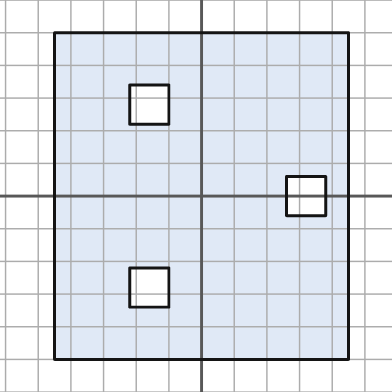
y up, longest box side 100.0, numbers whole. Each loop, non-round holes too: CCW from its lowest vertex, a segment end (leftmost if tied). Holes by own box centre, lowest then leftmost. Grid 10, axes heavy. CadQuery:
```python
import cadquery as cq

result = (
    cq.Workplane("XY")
    .moveTo(-45.0, -50.0)
    .lineTo(45.0, -50.0)
    .lineTo(45.0, 50.0)
    .lineTo(-45.0, 50.0)
    .close()
    .moveTo(-22.0, -34.0)
    .lineTo(-10.0, -34.0)
    .lineTo(-10.0, -22.0)
    .lineTo(-22.0, -22.0)
    .close()
    .moveTo(26.0, -6.0)
    .lineTo(38.0, -6.0)
    .lineTo(38.0, 6.0)
    .lineTo(26.0, 6.0)
    .close()
    .moveTo(-22.0, 22.0)
    .lineTo(-10.0, 22.0)
    .lineTo(-10.0, 34.0)
    .lineTo(-22.0, 34.0)
    .close()
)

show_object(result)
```